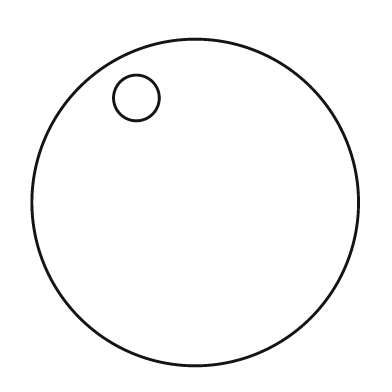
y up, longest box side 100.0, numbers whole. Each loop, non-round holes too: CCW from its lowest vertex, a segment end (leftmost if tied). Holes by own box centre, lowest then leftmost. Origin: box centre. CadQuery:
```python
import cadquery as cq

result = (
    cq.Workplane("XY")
    .moveTo(0.0, 0.0)
    .circle(50.0)
    .moveTo(-18.0, 32.0)
    .circle(7.0)
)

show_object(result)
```